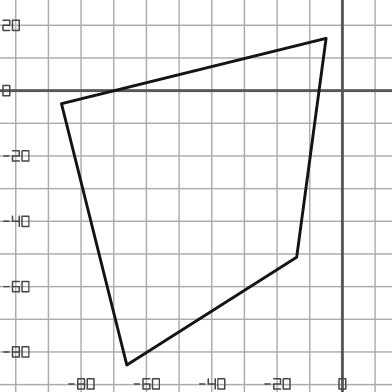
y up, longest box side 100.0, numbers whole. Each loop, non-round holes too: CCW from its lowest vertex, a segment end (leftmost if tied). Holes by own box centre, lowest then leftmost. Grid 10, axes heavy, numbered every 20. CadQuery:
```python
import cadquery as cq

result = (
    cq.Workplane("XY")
    .moveTo(-66.0, -84.0)
    .lineTo(-14.0, -51.0)
    .lineTo(-5.0, 16.0)
    .lineTo(-86.0, -4.0)
    .close()
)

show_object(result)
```